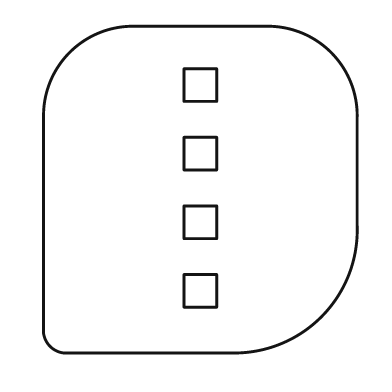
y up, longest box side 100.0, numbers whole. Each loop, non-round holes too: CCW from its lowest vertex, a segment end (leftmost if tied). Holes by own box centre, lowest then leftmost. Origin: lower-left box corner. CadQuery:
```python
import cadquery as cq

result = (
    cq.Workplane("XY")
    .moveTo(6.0, 0.0)
    .lineTo(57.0, 0.0)
    .threePointArc((85.0, 11.0), (96.0, 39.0))
    .lineTo(96.0, 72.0)
    .threePointArc((88.0, 92.0), (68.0, 100.0))
    .lineTo(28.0, 100.0)
    .threePointArc((8.0, 92.0), (0.0, 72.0))
    .lineTo(0.0, 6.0)
    .threePointArc((2.0, 2.0), (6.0, 0.0))
    .close()
    .moveTo(43.0, 14.0)
    .lineTo(53.0, 14.0)
    .lineTo(53.0, 24.0)
    .lineTo(43.0, 24.0)
    .close()
    .moveTo(43.0, 35.0)
    .lineTo(53.0, 35.0)
    .lineTo(53.0, 45.0)
    .lineTo(43.0, 45.0)
    .close()
    .moveTo(43.0, 56.0)
    .lineTo(53.0, 56.0)
    .lineTo(53.0, 66.0)
    .lineTo(43.0, 66.0)
    .close()
    .moveTo(43.0, 77.0)
    .lineTo(53.0, 77.0)
    .lineTo(53.0, 87.0)
    .lineTo(43.0, 87.0)
    .close()
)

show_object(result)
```